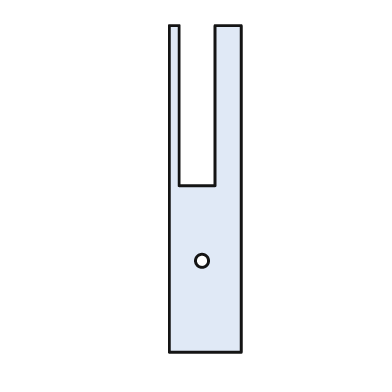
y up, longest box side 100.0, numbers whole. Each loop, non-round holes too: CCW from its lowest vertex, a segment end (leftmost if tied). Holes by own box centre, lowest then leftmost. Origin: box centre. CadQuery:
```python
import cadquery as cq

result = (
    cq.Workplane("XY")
    .moveTo(-11.0, -50.0)
    .lineTo(11.0, -50.0)
    .lineTo(11.0, 50.0)
    .lineTo(3.0, 50.0)
    .lineTo(3.0, 1.0)
    .lineTo(-8.0, 1.0)
    .lineTo(-8.0, 50.0)
    .lineTo(-11.0, 50.0)
    .close()
    .moveTo(-1.0, -22.0)
    .circle(2.0)
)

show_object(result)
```